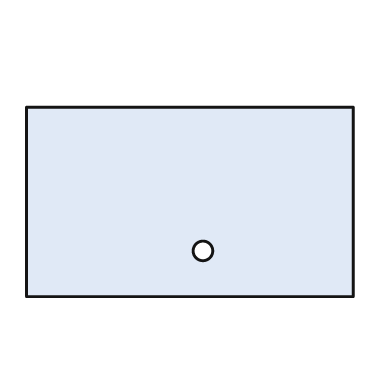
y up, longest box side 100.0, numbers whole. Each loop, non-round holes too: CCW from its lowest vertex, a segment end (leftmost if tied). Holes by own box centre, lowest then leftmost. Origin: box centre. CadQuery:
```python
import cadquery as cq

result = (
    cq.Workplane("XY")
    .moveTo(-50.0, -29.0)
    .lineTo(50.0, -29.0)
    .lineTo(50.0, 29.0)
    .lineTo(-50.0, 29.0)
    .close()
    .moveTo(4.0, -15.0)
    .circle(3.0)
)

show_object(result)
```